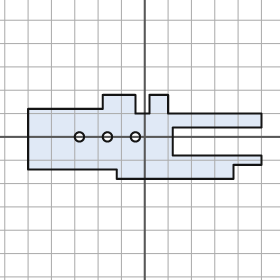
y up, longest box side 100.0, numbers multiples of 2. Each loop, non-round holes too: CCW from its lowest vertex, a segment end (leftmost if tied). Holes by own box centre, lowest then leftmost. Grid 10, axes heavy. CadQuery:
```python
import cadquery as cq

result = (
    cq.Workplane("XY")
    .moveTo(-12.0, -18.0)
    .lineTo(38.0, -18.0)
    .lineTo(38.0, -12.0)
    .lineTo(50.0, -12.0)
    .lineTo(50.0, -8.0)
    .lineTo(12.0, -8.0)
    .lineTo(12.0, 4.0)
    .lineTo(50.0, 4.0)
    .lineTo(50.0, 10.0)
    .lineTo(10.0, 10.0)
    .lineTo(10.0, 18.0)
    .lineTo(2.0, 18.0)
    .lineTo(2.0, 10.0)
    .lineTo(-4.0, 10.0)
    .lineTo(-4.0, 18.0)
    .lineTo(-18.0, 18.0)
    .lineTo(-18.0, 12.0)
    .lineTo(-50.0, 12.0)
    .lineTo(-50.0, -14.0)
    .lineTo(-12.0, -14.0)
    .close()
    .moveTo(-28.0, 0.0)
    .circle(2.0)
    .moveTo(-16.0, 0.0)
    .circle(2.0)
    .moveTo(-4.0, 0.0)
    .circle(2.0)
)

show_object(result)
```